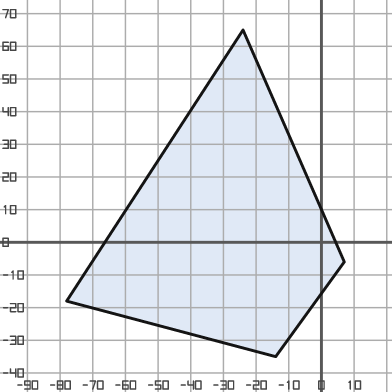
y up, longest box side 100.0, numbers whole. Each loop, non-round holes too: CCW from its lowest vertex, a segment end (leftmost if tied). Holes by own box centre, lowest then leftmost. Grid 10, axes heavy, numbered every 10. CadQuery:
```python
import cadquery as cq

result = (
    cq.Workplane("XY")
    .moveTo(-14.0, -35.0)
    .lineTo(7.0, -6.0)
    .lineTo(-24.0, 65.0)
    .lineTo(-78.0, -18.0)
    .close()
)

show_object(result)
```